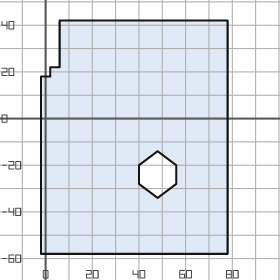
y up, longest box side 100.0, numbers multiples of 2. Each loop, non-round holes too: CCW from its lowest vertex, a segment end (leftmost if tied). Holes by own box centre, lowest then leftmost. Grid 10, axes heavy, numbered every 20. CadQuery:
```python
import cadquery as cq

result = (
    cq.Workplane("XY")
    .moveTo(-2.0, -58.0)
    .lineTo(78.0, -58.0)
    .lineTo(78.0, 42.0)
    .lineTo(6.0, 42.0)
    .lineTo(6.0, 22.0)
    .lineTo(2.0, 22.0)
    .lineTo(2.0, 18.0)
    .lineTo(-2.0, 18.0)
    .close()
    .moveTo(48.0, -34.0)
    .lineTo(56.0, -28.0)
    .lineTo(56.0, -20.0)
    .lineTo(48.0, -14.0)
    .lineTo(40.0, -20.0)
    .lineTo(40.0, -28.0)
    .close()
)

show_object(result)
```